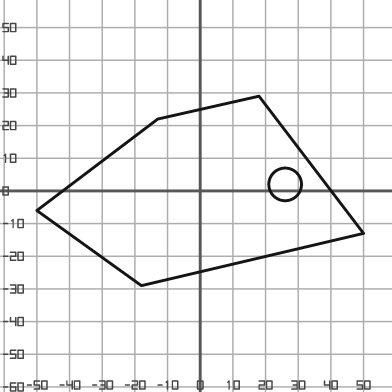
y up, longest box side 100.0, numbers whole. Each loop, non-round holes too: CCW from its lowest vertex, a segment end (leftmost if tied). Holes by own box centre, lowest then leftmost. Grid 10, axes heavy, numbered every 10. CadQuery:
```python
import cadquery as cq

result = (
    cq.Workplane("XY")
    .moveTo(-18.0, -29.0)
    .lineTo(50.0, -13.0)
    .lineTo(18.0, 29.0)
    .lineTo(-13.0, 22.0)
    .lineTo(-50.0, -6.0)
    .close()
    .moveTo(26.0, 2.0)
    .circle(5.0)
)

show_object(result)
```